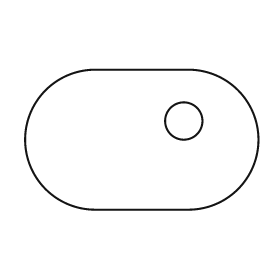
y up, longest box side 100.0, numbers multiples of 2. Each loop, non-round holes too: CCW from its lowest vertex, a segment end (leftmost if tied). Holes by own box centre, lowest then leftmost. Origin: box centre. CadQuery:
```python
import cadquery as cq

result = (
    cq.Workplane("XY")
    .moveTo(-20.0, -30.0)
    .lineTo(20.0, -30.0)
    .threePointArc((50.0, 0.0), (20.0, 30.0))
    .lineTo(-20.0, 30.0)
    .threePointArc((-50.0, 0.0), (-20.0, -30.0))
    .close()
    .moveTo(18.0, 8.0)
    .circle(8.0)
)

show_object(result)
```